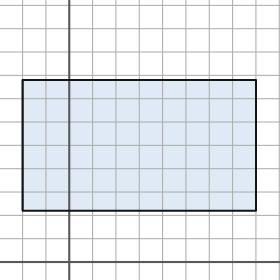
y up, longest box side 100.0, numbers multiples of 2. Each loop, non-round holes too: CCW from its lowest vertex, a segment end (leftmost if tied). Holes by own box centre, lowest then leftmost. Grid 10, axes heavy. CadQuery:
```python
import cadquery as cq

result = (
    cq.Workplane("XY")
    .moveTo(-20.0, 22.0)
    .lineTo(80.0, 22.0)
    .lineTo(80.0, 78.0)
    .lineTo(-20.0, 78.0)
    .close()
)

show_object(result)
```